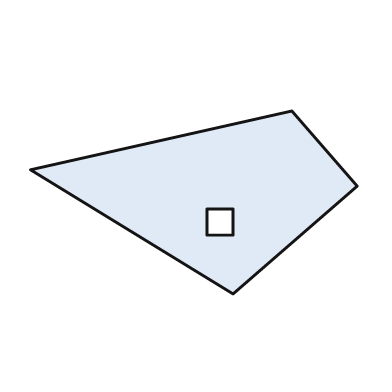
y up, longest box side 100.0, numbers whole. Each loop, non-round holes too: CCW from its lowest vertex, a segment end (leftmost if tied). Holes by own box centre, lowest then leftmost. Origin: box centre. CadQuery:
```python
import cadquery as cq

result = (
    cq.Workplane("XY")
    .moveTo(12.0, -28.0)
    .lineTo(50.0, 5.0)
    .lineTo(30.0, 28.0)
    .lineTo(-50.0, 10.0)
    .close()
    .moveTo(4.0, -10.0)
    .lineTo(12.0, -10.0)
    .lineTo(12.0, -2.0)
    .lineTo(4.0, -2.0)
    .close()
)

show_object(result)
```